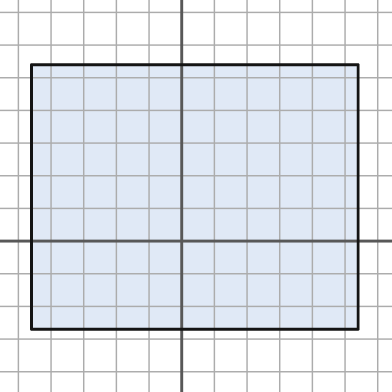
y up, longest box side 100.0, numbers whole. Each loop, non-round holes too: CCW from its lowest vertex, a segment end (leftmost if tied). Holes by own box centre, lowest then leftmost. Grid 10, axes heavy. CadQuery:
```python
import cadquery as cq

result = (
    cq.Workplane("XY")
    .moveTo(-46.0, -27.0)
    .lineTo(54.0, -27.0)
    .lineTo(54.0, 54.0)
    .lineTo(-46.0, 54.0)
    .close()
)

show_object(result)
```